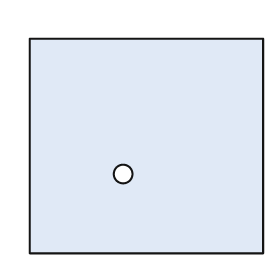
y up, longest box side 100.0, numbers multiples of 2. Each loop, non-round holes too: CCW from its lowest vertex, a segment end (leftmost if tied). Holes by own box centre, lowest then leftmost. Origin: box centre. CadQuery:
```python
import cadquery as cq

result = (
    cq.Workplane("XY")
    .moveTo(-50.0, -46.0)
    .lineTo(50.0, -46.0)
    .lineTo(50.0, 46.0)
    .lineTo(-50.0, 46.0)
    .close()
    .moveTo(-10.0, -12.0)
    .circle(4.0)
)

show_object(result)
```